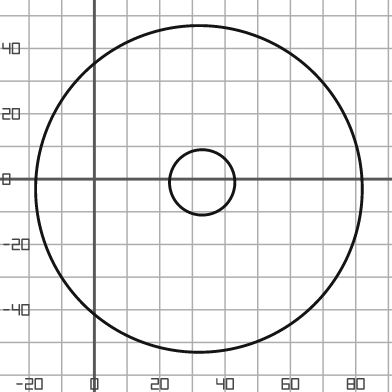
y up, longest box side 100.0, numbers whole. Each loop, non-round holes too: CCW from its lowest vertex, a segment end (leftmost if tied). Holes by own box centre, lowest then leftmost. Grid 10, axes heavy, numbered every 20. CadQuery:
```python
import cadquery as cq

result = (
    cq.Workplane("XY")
    .moveTo(32.0, -3.0)
    .circle(50.0)
    .moveTo(33.0, -1.0)
    .circle(10.0)
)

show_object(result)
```